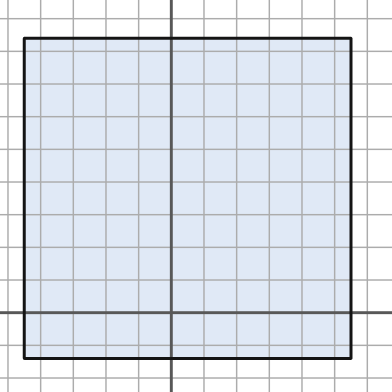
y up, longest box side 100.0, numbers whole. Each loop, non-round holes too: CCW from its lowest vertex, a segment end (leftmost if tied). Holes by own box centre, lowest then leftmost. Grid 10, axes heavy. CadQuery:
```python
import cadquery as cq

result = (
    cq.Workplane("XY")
    .moveTo(-45.0, -14.0)
    .lineTo(55.0, -14.0)
    .lineTo(55.0, 84.0)
    .lineTo(-45.0, 84.0)
    .close()
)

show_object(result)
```